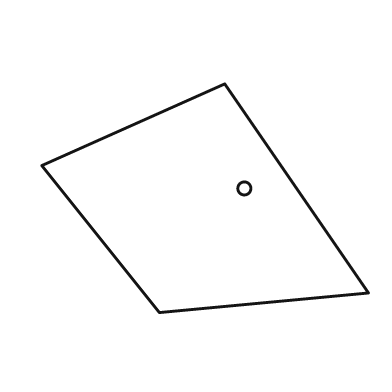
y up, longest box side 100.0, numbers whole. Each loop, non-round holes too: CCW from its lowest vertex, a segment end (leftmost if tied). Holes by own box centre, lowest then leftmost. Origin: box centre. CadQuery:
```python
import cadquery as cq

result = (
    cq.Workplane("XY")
    .moveTo(-14.0, -35.0)
    .lineTo(50.0, -29.0)
    .lineTo(6.0, 35.0)
    .lineTo(-50.0, 10.0)
    .close()
    .moveTo(12.0, 3.0)
    .circle(2.0)
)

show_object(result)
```